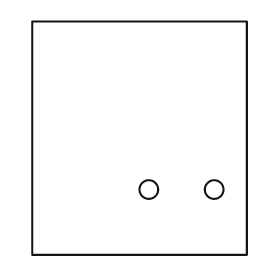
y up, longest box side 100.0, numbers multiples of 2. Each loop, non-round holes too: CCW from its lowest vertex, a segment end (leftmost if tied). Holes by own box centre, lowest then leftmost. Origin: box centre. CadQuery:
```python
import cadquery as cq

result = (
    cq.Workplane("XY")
    .moveTo(-46.0, -50.0)
    .lineTo(46.0, -50.0)
    .lineTo(46.0, 50.0)
    .lineTo(-46.0, 50.0)
    .close()
    .moveTo(4.0, -22.0)
    .circle(4.0)
    .moveTo(32.0, -22.0)
    .circle(4.0)
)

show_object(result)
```